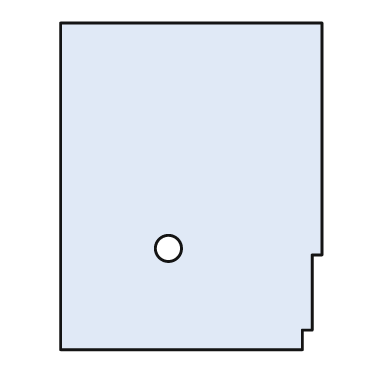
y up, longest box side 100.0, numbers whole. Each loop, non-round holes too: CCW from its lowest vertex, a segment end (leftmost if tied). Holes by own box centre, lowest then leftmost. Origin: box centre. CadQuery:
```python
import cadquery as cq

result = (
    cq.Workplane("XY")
    .moveTo(-40.0, -50.0)
    .lineTo(34.0, -50.0)
    .lineTo(34.0, -44.0)
    .lineTo(37.0, -44.0)
    .lineTo(37.0, -21.0)
    .lineTo(40.0, -21.0)
    .lineTo(40.0, 50.0)
    .lineTo(-40.0, 50.0)
    .close()
    .moveTo(-7.0, -19.0)
    .circle(4.0)
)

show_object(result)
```